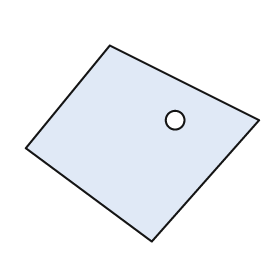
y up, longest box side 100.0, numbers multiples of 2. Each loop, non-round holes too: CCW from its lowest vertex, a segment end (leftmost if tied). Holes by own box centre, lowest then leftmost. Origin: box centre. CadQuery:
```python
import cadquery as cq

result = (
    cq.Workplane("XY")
    .moveTo(4.0, -42.0)
    .lineTo(50.0, 10.0)
    .lineTo(-14.0, 42.0)
    .lineTo(-50.0, -2.0)
    .close()
    .moveTo(14.0, 10.0)
    .circle(4.0)
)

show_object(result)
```